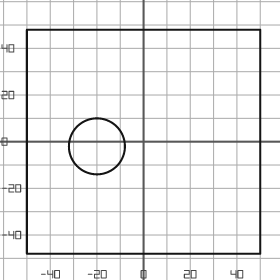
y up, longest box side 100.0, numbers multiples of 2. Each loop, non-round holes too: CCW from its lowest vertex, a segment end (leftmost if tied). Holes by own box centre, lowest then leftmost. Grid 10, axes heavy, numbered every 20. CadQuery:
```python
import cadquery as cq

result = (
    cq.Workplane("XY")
    .moveTo(-50.0, -48.0)
    .lineTo(50.0, -48.0)
    .lineTo(50.0, 48.0)
    .lineTo(-50.0, 48.0)
    .close()
    .moveTo(-20.0, -2.0)
    .circle(12.0)
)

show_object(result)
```